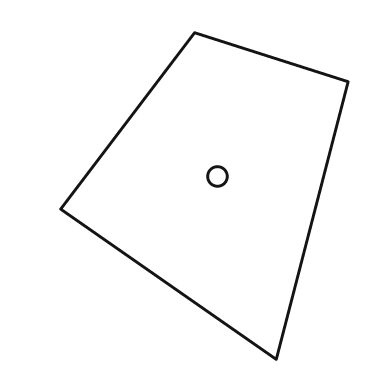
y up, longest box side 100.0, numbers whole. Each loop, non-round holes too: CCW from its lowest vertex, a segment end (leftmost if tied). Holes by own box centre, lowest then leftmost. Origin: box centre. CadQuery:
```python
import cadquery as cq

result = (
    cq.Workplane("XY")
    .moveTo(22.0, -50.0)
    .lineTo(44.0, 35.0)
    .lineTo(-3.0, 50.0)
    .lineTo(-44.0, -4.0)
    .close()
    .moveTo(4.0, 6.0)
    .circle(3.0)
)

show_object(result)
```